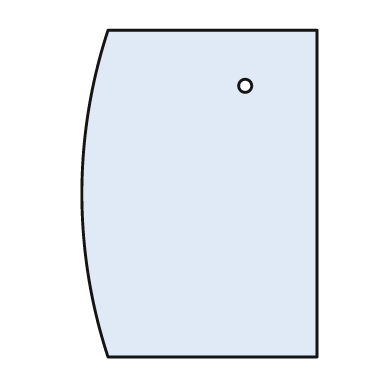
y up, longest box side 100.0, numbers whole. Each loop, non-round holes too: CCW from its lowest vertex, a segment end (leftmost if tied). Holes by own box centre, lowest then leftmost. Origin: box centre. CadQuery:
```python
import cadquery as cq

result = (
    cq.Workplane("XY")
    .moveTo(-28.0, -50.0)
    .lineTo(36.0, -50.0)
    .lineTo(36.0, 50.0)
    .lineTo(-28.0, 50.0)
    .threePointArc((-36.0, 0.0), (-28.0, -50.0))
    .close()
    .moveTo(14.0, 33.0)
    .circle(2.0)
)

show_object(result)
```